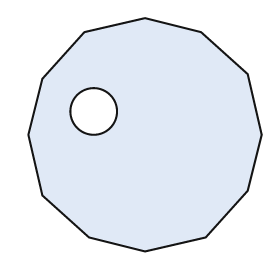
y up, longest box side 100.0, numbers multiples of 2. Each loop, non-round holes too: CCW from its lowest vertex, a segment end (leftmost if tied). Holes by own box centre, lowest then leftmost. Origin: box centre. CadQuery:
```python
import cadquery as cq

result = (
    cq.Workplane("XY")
    .moveTo(0.0, -50.0)
    .lineTo(26.0, -44.0)
    .lineTo(44.0, -24.0)
    .lineTo(50.0, 0.0)
    .lineTo(44.0, 26.0)
    .lineTo(24.0, 44.0)
    .lineTo(0.0, 50.0)
    .lineTo(-26.0, 44.0)
    .lineTo(-44.0, 24.0)
    .lineTo(-50.0, 0.0)
    .lineTo(-44.0, -26.0)
    .lineTo(-24.0, -44.0)
    .close()
    .moveTo(-22.0, 10.0)
    .circle(10.0)
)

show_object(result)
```